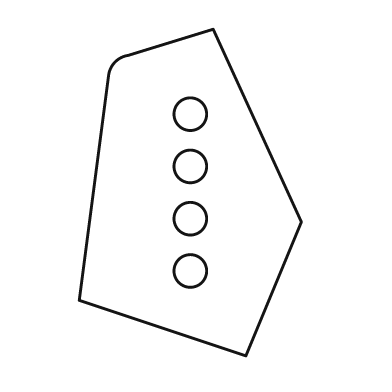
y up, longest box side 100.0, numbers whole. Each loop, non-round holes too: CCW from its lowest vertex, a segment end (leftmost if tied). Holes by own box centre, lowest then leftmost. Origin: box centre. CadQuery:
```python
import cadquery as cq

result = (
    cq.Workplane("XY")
    .moveTo(17.0, -50.0)
    .lineTo(34.0, -9.0)
    .lineTo(7.0, 50.0)
    .lineTo(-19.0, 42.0)
    .threePointArc((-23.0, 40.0), (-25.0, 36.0))
    .lineTo(-34.0, -33.0)
    .close()
    .moveTo(0.0, -24.0)
    .circle(5.0)
    .moveTo(0.0, -8.0)
    .circle(5.0)
    .moveTo(0.0, 8.0)
    .circle(5.0)
    .moveTo(0.0, 24.0)
    .circle(5.0)
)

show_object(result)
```